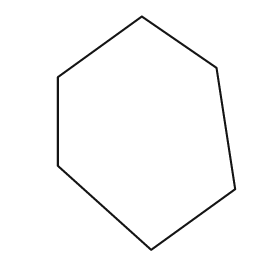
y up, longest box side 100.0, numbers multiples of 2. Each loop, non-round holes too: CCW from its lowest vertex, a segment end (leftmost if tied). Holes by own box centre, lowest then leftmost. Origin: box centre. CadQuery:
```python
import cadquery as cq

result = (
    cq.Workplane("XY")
    .moveTo(2.0, -50.0)
    .lineTo(38.0, -24.0)
    .lineTo(30.0, 28.0)
    .lineTo(-2.0, 50.0)
    .lineTo(-38.0, 24.0)
    .lineTo(-38.0, -14.0)
    .close()
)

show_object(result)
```